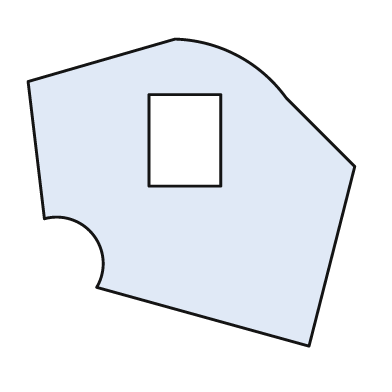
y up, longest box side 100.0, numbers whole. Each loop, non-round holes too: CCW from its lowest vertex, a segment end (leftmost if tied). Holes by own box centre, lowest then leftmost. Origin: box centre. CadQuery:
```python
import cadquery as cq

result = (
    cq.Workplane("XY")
    .moveTo(36.0, -47.0)
    .lineTo(50.0, 8.0)
    .lineTo(29.0, 29.0)
    .threePointArc((14.0, 42.0), (-5.0, 47.0))
    .lineTo(-50.0, 34.0)
    .lineTo(-45.0, -8.0)
    .threePointArc((-30.0, -13.0), (-29.0, -29.0))
    .close()
    .moveTo(-13.0, 2.0)
    .lineTo(9.0, 2.0)
    .lineTo(9.0, 30.0)
    .lineTo(-13.0, 30.0)
    .close()
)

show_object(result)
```